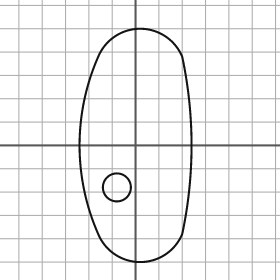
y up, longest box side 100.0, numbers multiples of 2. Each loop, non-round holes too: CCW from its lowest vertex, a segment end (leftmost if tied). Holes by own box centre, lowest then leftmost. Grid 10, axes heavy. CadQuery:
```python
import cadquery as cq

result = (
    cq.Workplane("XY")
    .moveTo(-16.0, -38.0)
    .threePointArc((2.0, -50.0), (20.0, -38.0))
    .threePointArc((24.0, 0.0), (20.0, 38.0))
    .threePointArc((2.0, 50.0), (-16.0, 38.0))
    .threePointArc((-24.0, 0.0), (-16.0, -38.0))
    .close()
    .moveTo(-8.0, -18.0)
    .circle(6.0)
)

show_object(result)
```